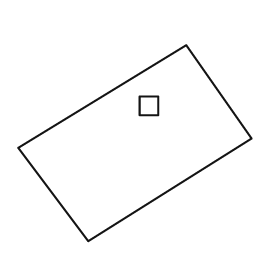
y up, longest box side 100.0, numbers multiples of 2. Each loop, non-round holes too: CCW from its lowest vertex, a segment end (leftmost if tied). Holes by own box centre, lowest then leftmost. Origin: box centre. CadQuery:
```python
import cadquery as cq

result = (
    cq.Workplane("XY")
    .moveTo(-20.0, -42.0)
    .lineTo(50.0, 2.0)
    .lineTo(22.0, 42.0)
    .lineTo(-50.0, -2.0)
    .close()
    .moveTo(2.0, 12.0)
    .lineTo(10.0, 12.0)
    .lineTo(10.0, 20.0)
    .lineTo(2.0, 20.0)
    .close()
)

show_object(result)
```